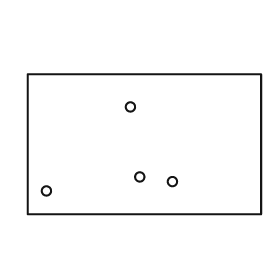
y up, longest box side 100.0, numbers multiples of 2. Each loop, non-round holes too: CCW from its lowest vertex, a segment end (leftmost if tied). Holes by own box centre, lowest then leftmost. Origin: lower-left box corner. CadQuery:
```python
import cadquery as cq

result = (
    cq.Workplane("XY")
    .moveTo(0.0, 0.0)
    .lineTo(100.0, 0.0)
    .lineTo(100.0, 60.0)
    .lineTo(0.0, 60.0)
    .close()
    .moveTo(8.0, 10.0)
    .circle(2.0)
    .moveTo(62.0, 14.0)
    .circle(2.0)
    .moveTo(48.0, 16.0)
    .circle(2.0)
    .moveTo(44.0, 46.0)
    .circle(2.0)
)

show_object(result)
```